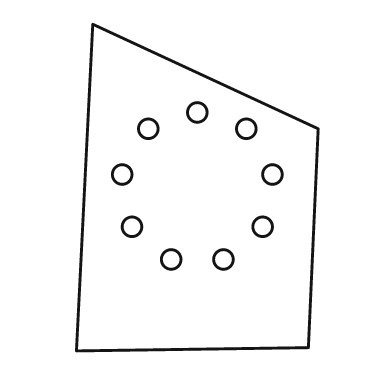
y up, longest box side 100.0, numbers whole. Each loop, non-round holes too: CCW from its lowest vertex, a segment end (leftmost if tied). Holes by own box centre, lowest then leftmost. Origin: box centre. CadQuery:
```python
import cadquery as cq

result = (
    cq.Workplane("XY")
    .moveTo(-37.0, -50.0)
    .lineTo(34.0, -49.0)
    .lineTo(37.0, 18.0)
    .lineTo(-32.0, 50.0)
    .close()
    .moveTo(-8.0, -22.0)
    .circle(3.0)
    .moveTo(8.0, -22.0)
    .circle(3.0)
    .moveTo(-20.0, -12.0)
    .circle(3.0)
    .moveTo(20.0, -12.0)
    .circle(3.0)
    .moveTo(-23.0, 4.0)
    .circle(3.0)
    .moveTo(23.0, 4.0)
    .circle(3.0)
    .moveTo(-15.0, 18.0)
    .circle(3.0)
    .moveTo(15.0, 18.0)
    .circle(3.0)
    .moveTo(0.0, 23.0)
    .circle(3.0)
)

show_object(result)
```